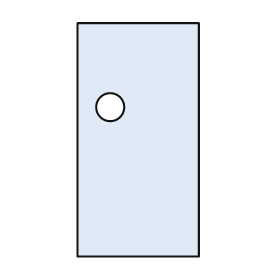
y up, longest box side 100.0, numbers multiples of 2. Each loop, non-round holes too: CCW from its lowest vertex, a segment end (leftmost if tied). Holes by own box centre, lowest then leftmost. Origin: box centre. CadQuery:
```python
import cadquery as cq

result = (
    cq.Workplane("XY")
    .moveTo(-26.0, -50.0)
    .lineTo(26.0, -50.0)
    .lineTo(26.0, 50.0)
    .lineTo(-26.0, 50.0)
    .close()
    .moveTo(-12.0, 14.0)
    .circle(6.0)
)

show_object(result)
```